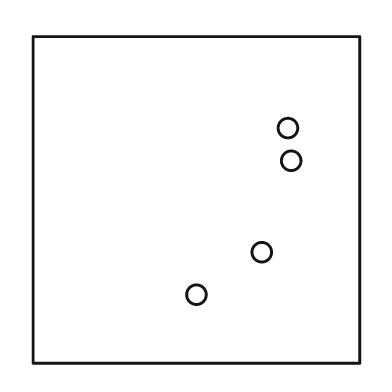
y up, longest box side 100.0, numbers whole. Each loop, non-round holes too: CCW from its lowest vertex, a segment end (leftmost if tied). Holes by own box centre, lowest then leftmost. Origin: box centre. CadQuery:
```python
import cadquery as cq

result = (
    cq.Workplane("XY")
    .moveTo(-50.0, -50.0)
    .lineTo(50.0, -50.0)
    .lineTo(50.0, 50.0)
    .lineTo(-50.0, 50.0)
    .close()
    .moveTo(0.0, -29.0)
    .circle(3.0)
    .moveTo(20.0, -16.0)
    .circle(3.0)
    .moveTo(29.0, 12.0)
    .circle(3.0)
    .moveTo(28.0, 22.0)
    .circle(3.0)
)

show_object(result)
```